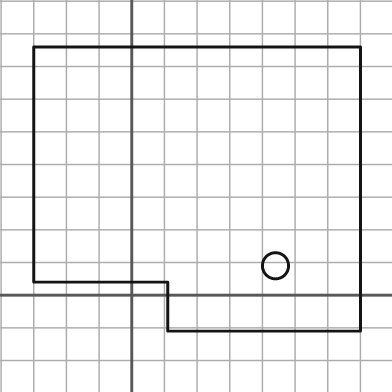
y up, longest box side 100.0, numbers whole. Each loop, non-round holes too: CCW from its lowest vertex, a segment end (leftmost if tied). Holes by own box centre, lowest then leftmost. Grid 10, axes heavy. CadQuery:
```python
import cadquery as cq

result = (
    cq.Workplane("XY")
    .moveTo(11.0, -11.0)
    .lineTo(70.0, -11.0)
    .lineTo(70.0, 76.0)
    .lineTo(-30.0, 76.0)
    .lineTo(-30.0, 4.0)
    .lineTo(11.0, 4.0)
    .close()
    .moveTo(44.0, 9.0)
    .circle(4.0)
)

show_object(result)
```